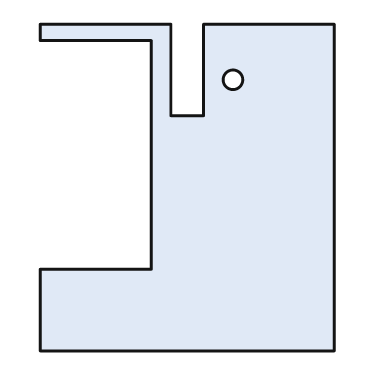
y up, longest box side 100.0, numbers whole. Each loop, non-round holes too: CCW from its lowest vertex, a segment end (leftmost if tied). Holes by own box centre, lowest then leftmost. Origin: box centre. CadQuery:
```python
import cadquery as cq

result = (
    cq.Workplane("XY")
    .moveTo(-45.0, -50.0)
    .lineTo(45.0, -50.0)
    .lineTo(45.0, 50.0)
    .lineTo(5.0, 50.0)
    .lineTo(5.0, 22.0)
    .lineTo(-5.0, 22.0)
    .lineTo(-5.0, 50.0)
    .lineTo(-45.0, 50.0)
    .lineTo(-45.0, 45.0)
    .lineTo(-11.0, 45.0)
    .lineTo(-11.0, -25.0)
    .lineTo(-45.0, -25.0)
    .close()
    .moveTo(14.0, 33.0)
    .circle(3.0)
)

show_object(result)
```